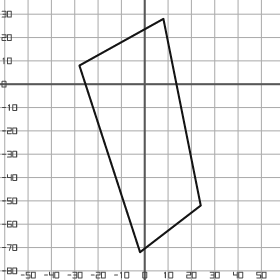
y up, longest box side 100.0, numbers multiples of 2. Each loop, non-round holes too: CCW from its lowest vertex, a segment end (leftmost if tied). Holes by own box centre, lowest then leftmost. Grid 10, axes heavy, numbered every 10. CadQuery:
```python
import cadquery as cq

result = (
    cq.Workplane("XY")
    .moveTo(-2.0, -72.0)
    .lineTo(24.0, -52.0)
    .lineTo(8.0, 28.0)
    .lineTo(-28.0, 8.0)
    .close()
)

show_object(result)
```